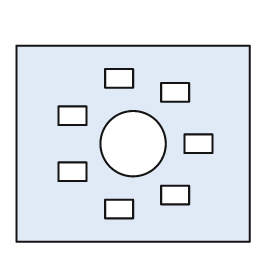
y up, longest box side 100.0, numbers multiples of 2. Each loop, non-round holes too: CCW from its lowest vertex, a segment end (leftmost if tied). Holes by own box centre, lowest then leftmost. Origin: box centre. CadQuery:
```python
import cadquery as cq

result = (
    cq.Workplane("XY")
    .moveTo(-50.0, -42.0)
    .lineTo(50.0, -42.0)
    .lineTo(50.0, 42.0)
    .lineTo(-50.0, 42.0)
    .close()
    .moveTo(-12.0, -32.0)
    .lineTo(0.0, -32.0)
    .lineTo(0.0, -24.0)
    .lineTo(-12.0, -24.0)
    .close()
    .moveTo(12.0, -26.0)
    .lineTo(24.0, -26.0)
    .lineTo(24.0, -18.0)
    .lineTo(12.0, -18.0)
    .close()
    .moveTo(-32.0, -16.0)
    .lineTo(-20.0, -16.0)
    .lineTo(-20.0, -8.0)
    .lineTo(-32.0, -8.0)
    .close()
    .moveTo(0.0, 0.0)
    .circle(14.0)
    .moveTo(22.0, -4.0)
    .lineTo(34.0, -4.0)
    .lineTo(34.0, 4.0)
    .lineTo(22.0, 4.0)
    .close()
    .moveTo(-32.0, 8.0)
    .lineTo(-20.0, 8.0)
    .lineTo(-20.0, 16.0)
    .lineTo(-32.0, 16.0)
    .close()
    .moveTo(12.0, 18.0)
    .lineTo(24.0, 18.0)
    .lineTo(24.0, 26.0)
    .lineTo(12.0, 26.0)
    .close()
    .moveTo(-12.0, 24.0)
    .lineTo(0.0, 24.0)
    .lineTo(0.0, 32.0)
    .lineTo(-12.0, 32.0)
    .close()
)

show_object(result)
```